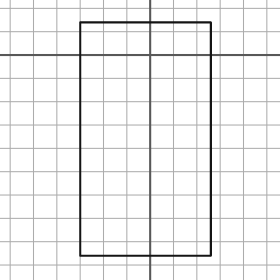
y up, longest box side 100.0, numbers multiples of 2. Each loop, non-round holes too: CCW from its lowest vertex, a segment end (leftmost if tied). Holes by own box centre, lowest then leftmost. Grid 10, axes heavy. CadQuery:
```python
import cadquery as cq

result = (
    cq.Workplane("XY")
    .moveTo(-30.0, -86.0)
    .lineTo(26.0, -86.0)
    .lineTo(26.0, 14.0)
    .lineTo(-30.0, 14.0)
    .close()
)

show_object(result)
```